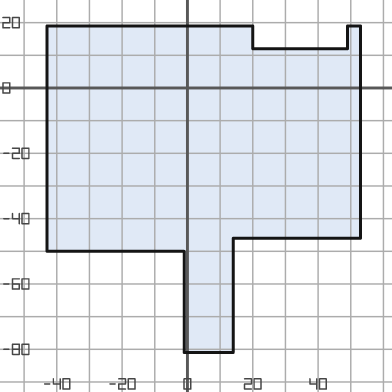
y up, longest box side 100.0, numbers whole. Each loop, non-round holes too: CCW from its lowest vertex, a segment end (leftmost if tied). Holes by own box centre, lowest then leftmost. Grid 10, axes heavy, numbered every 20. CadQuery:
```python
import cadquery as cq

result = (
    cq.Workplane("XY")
    .moveTo(-1.0, -81.0)
    .lineTo(14.0, -81.0)
    .lineTo(14.0, -46.0)
    .lineTo(53.0, -46.0)
    .lineTo(53.0, 19.0)
    .lineTo(49.0, 19.0)
    .lineTo(49.0, 12.0)
    .lineTo(20.0, 12.0)
    .lineTo(20.0, 19.0)
    .lineTo(-43.0, 19.0)
    .lineTo(-43.0, -50.0)
    .lineTo(-1.0, -50.0)
    .close()
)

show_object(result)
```